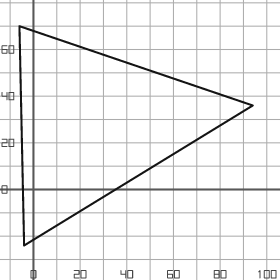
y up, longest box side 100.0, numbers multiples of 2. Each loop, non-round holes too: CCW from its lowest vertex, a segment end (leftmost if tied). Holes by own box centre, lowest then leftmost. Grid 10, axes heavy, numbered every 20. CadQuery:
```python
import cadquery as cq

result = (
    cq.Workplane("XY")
    .moveTo(-4.0, -24.0)
    .lineTo(94.0, 36.0)
    .lineTo(-6.0, 70.0)
    .close()
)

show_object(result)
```